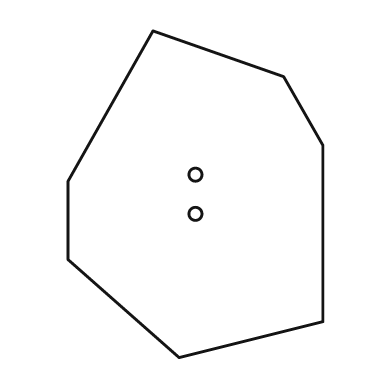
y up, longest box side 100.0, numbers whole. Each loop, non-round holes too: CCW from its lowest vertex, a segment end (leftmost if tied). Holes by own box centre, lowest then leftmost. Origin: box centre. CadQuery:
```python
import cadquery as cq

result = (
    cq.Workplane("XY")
    .moveTo(-5.0, -50.0)
    .lineTo(39.0, -39.0)
    .lineTo(39.0, 15.0)
    .lineTo(27.0, 36.0)
    .lineTo(-13.0, 50.0)
    .lineTo(-39.0, 4.0)
    .lineTo(-39.0, -20.0)
    .close()
    .moveTo(0.0, -6.0)
    .circle(2.0)
    .moveTo(0.0, 6.0)
    .circle(2.0)
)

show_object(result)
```